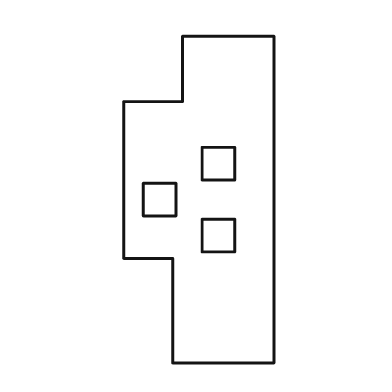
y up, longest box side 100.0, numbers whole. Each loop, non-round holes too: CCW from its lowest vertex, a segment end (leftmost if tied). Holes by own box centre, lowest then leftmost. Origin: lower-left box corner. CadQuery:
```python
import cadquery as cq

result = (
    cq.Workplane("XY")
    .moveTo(15.0, 0.0)
    .lineTo(46.0, 0.0)
    .lineTo(46.0, 100.0)
    .lineTo(18.0, 100.0)
    .lineTo(18.0, 80.0)
    .lineTo(0.0, 80.0)
    .lineTo(0.0, 32.0)
    .lineTo(15.0, 32.0)
    .close()
    .moveTo(24.0, 34.0)
    .lineTo(34.0, 34.0)
    .lineTo(34.0, 44.0)
    .lineTo(24.0, 44.0)
    .close()
    .moveTo(6.0, 45.0)
    .lineTo(16.0, 45.0)
    .lineTo(16.0, 55.0)
    .lineTo(6.0, 55.0)
    .close()
    .moveTo(24.0, 56.0)
    .lineTo(34.0, 56.0)
    .lineTo(34.0, 66.0)
    .lineTo(24.0, 66.0)
    .close()
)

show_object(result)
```